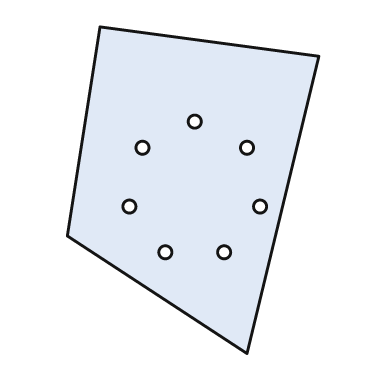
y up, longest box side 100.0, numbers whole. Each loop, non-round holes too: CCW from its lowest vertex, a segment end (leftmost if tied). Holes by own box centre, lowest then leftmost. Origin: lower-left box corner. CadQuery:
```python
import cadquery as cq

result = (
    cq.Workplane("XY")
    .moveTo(55.0, 0.0)
    .lineTo(77.0, 91.0)
    .lineTo(10.0, 100.0)
    .lineTo(0.0, 36.0)
    .close()
    .moveTo(30.0, 31.0)
    .circle(2.0)
    .moveTo(48.0, 31.0)
    .circle(2.0)
    .moveTo(19.0, 45.0)
    .circle(2.0)
    .moveTo(59.0, 45.0)
    .circle(2.0)
    .moveTo(23.0, 63.0)
    .circle(2.0)
    .moveTo(55.0, 63.0)
    .circle(2.0)
    .moveTo(39.0, 71.0)
    .circle(2.0)
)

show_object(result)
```